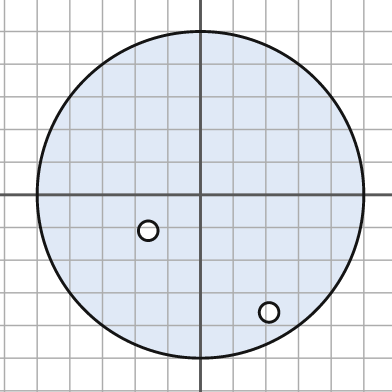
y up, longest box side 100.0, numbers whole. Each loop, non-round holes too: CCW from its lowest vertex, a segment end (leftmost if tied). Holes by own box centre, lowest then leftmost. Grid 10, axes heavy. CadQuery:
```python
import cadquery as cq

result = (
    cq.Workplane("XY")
    .moveTo(0.0, 0.0)
    .circle(50.0)
    .moveTo(21.0, -36.0)
    .circle(3.0)
    .moveTo(-16.0, -11.0)
    .circle(3.0)
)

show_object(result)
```